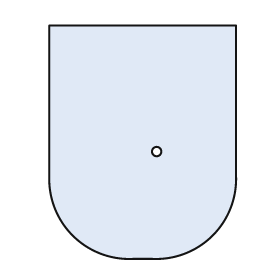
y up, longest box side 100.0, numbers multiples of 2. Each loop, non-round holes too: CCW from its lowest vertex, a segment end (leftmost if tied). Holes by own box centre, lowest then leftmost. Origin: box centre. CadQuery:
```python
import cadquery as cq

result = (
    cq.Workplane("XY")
    .moveTo(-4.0, -50.0)
    .lineTo(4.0, -50.0)
    .threePointArc((30.0, -40.0), (40.0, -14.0))
    .lineTo(40.0, 50.0)
    .lineTo(-40.0, 50.0)
    .lineTo(-40.0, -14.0)
    .threePointArc((-30.0, -40.0), (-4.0, -50.0))
    .close()
    .moveTo(6.0, -4.0)
    .circle(2.0)
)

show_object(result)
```